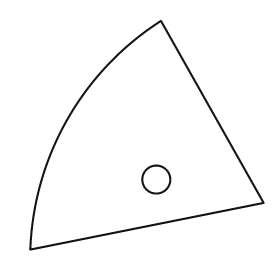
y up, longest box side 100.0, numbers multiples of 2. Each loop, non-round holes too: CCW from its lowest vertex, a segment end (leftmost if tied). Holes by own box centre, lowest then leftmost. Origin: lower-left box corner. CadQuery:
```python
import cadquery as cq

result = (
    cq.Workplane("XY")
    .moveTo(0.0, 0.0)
    .lineTo(100.0, 20.0)
    .lineTo(56.0, 98.0)
    .threePointArc((16.0, 56.0), (0.0, 0.0))
    .close()
    .moveTo(54.0, 30.0)
    .circle(6.0)
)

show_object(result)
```